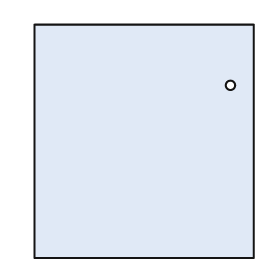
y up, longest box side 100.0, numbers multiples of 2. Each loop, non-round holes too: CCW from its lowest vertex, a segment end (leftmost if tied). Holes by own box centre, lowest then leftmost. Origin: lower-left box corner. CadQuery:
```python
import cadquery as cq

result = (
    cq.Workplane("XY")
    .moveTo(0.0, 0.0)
    .lineTo(94.0, 0.0)
    .lineTo(94.0, 100.0)
    .lineTo(0.0, 100.0)
    .close()
    .moveTo(84.0, 74.0)
    .circle(2.0)
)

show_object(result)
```